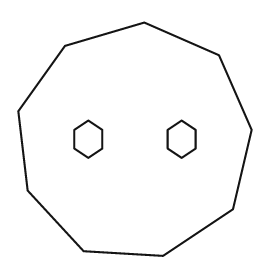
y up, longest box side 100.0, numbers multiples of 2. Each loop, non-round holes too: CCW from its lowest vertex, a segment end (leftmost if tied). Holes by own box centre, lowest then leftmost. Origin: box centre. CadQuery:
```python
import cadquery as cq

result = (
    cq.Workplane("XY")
    .moveTo(12.0, -50.0)
    .lineTo(42.0, -30.0)
    .lineTo(50.0, 4.0)
    .lineTo(36.0, 36.0)
    .lineTo(4.0, 50.0)
    .lineTo(-30.0, 40.0)
    .lineTo(-50.0, 12.0)
    .lineTo(-46.0, -22.0)
    .lineTo(-22.0, -48.0)
    .close()
    .moveTo(-20.0, -8.0)
    .lineTo(-14.0, -4.0)
    .lineTo(-14.0, 4.0)
    .lineTo(-20.0, 8.0)
    .lineTo(-26.0, 4.0)
    .lineTo(-26.0, -4.0)
    .close()
    .moveTo(20.0, -8.0)
    .lineTo(26.0, -4.0)
    .lineTo(26.0, 4.0)
    .lineTo(20.0, 8.0)
    .lineTo(14.0, 4.0)
    .lineTo(14.0, -4.0)
    .close()
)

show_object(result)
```